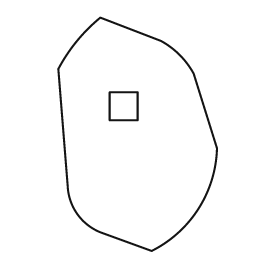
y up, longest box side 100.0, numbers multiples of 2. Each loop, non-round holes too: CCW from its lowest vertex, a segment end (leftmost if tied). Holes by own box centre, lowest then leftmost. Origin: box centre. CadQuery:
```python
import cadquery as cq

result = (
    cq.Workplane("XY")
    .moveTo(6.0, -50.0)
    .threePointArc((26.0, -32.0), (34.0, -6.0))
    .lineTo(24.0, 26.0)
    .threePointArc((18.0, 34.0), (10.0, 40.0))
    .lineTo(-16.0, 50.0)
    .threePointArc((-26.0, 40.0), (-34.0, 28.0))
    .lineTo(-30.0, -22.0)
    .threePointArc((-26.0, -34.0), (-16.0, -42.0))
    .close()
    .moveTo(-12.0, 6.0)
    .lineTo(0.0, 6.0)
    .lineTo(0.0, 18.0)
    .lineTo(-12.0, 18.0)
    .close()
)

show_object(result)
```